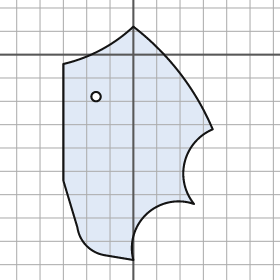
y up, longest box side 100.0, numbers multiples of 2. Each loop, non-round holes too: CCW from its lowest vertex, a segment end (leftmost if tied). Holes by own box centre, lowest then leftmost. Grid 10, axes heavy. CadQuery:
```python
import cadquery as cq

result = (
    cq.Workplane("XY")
    .moveTo(0.0, -88.0)
    .threePointArc((6.0, -68.0), (26.0, -64.0))
    .threePointArc((22.0, -46.0), (34.0, -32.0))
    .threePointArc((20.0, -8.0), (0.0, 12.0))
    .threePointArc((-14.0, 2.0), (-30.0, -4.0))
    .lineTo(-30.0, -54.0)
    .lineTo(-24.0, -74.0)
    .threePointArc((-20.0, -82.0), (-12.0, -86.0))
    .close()
    .moveTo(-16.0, -18.0)
    .circle(2.0)
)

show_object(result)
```